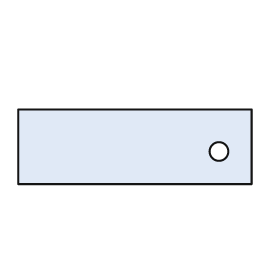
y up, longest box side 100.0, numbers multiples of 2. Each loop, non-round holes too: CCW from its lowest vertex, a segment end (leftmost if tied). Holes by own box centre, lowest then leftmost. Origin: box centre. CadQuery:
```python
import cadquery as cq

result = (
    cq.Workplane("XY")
    .moveTo(-50.0, -16.0)
    .lineTo(50.0, -16.0)
    .lineTo(50.0, 16.0)
    .lineTo(-50.0, 16.0)
    .close()
    .moveTo(36.0, -2.0)
    .circle(4.0)
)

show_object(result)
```